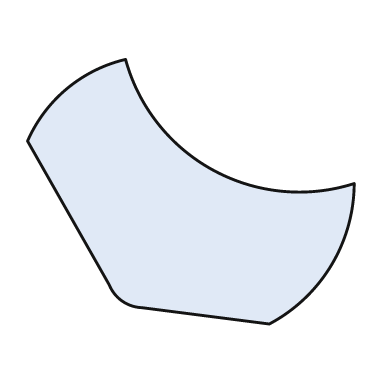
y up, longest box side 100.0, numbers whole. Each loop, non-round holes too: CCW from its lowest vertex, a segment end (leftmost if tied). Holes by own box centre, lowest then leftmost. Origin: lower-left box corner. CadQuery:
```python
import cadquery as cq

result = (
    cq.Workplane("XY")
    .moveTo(74.0, 0.0)
    .threePointArc((93.0, 18.0), (100.0, 43.0))
    .threePointArc((57.0, 47.0), (30.0, 81.0))
    .threePointArc((12.0, 72.0), (0.0, 56.0))
    .lineTo(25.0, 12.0)
    .threePointArc((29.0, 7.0), (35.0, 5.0))
    .close()
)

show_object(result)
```